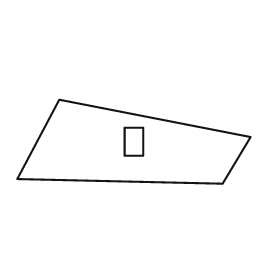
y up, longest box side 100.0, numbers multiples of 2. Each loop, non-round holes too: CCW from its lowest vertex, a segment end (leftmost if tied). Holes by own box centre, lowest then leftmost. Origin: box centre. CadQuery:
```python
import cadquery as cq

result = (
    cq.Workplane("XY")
    .moveTo(38.0, -18.0)
    .lineTo(50.0, 2.0)
    .lineTo(-32.0, 18.0)
    .lineTo(-50.0, -16.0)
    .close()
    .moveTo(-4.0, -6.0)
    .lineTo(4.0, -6.0)
    .lineTo(4.0, 6.0)
    .lineTo(-4.0, 6.0)
    .close()
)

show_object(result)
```